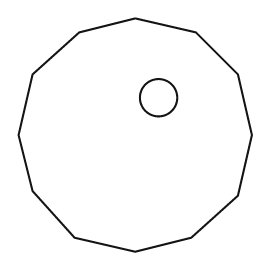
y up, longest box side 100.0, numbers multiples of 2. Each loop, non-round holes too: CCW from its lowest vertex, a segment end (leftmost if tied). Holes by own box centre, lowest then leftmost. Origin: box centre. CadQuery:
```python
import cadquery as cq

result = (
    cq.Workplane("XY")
    .moveTo(0.0, -50.0)
    .lineTo(24.0, -44.0)
    .lineTo(44.0, -26.0)
    .lineTo(50.0, 0.0)
    .lineTo(44.0, 26.0)
    .lineTo(26.0, 44.0)
    .lineTo(0.0, 50.0)
    .lineTo(-24.0, 44.0)
    .lineTo(-44.0, 26.0)
    .lineTo(-50.0, 0.0)
    .lineTo(-44.0, -24.0)
    .lineTo(-26.0, -44.0)
    .close()
    .moveTo(10.0, 16.0)
    .circle(8.0)
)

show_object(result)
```